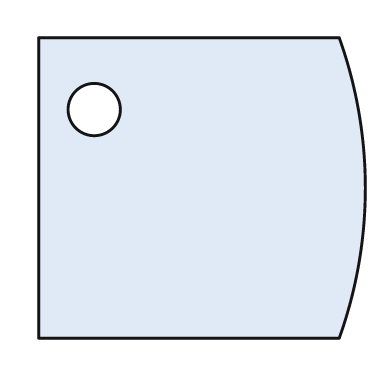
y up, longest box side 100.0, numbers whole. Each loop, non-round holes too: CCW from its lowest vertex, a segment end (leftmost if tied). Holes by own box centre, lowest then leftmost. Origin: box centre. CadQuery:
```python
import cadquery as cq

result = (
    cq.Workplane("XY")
    .moveTo(-50.0, -46.0)
    .lineTo(42.0, -46.0)
    .threePointArc((50.0, 0.0), (42.0, 46.0))
    .lineTo(-50.0, 46.0)
    .close()
    .moveTo(-33.0, 24.0)
    .circle(8.0)
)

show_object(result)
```